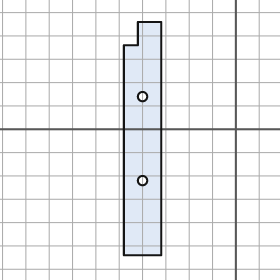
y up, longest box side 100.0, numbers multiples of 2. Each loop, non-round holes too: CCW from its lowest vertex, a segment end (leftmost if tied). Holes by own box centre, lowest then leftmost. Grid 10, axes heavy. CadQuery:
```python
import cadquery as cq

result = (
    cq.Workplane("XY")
    .moveTo(-48.0, -54.0)
    .lineTo(-32.0, -54.0)
    .lineTo(-32.0, 46.0)
    .lineTo(-42.0, 46.0)
    .lineTo(-42.0, 36.0)
    .lineTo(-48.0, 36.0)
    .close()
    .moveTo(-40.0, -22.0)
    .circle(2.0)
    .moveTo(-40.0, 14.0)
    .circle(2.0)
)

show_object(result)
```